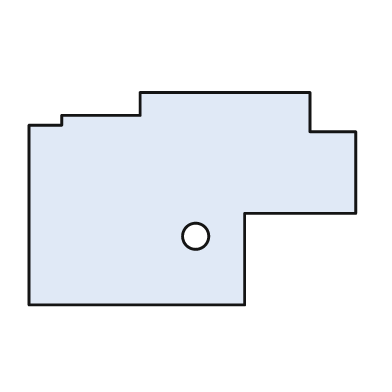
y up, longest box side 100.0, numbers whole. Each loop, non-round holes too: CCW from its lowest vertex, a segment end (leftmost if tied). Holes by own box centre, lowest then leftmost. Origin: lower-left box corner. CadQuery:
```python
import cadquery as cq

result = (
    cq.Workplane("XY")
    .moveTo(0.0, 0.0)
    .lineTo(66.0, 0.0)
    .lineTo(66.0, 28.0)
    .lineTo(100.0, 28.0)
    .lineTo(100.0, 53.0)
    .lineTo(86.0, 53.0)
    .lineTo(86.0, 65.0)
    .lineTo(34.0, 65.0)
    .lineTo(34.0, 58.0)
    .lineTo(10.0, 58.0)
    .lineTo(10.0, 55.0)
    .lineTo(0.0, 55.0)
    .close()
    .moveTo(51.0, 21.0)
    .circle(4.0)
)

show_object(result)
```